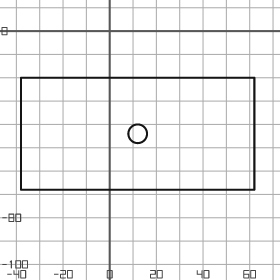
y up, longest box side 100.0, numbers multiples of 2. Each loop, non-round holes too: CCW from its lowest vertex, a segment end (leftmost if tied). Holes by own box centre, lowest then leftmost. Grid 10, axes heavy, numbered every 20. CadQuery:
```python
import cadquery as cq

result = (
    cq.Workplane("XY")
    .moveTo(-38.0, -68.0)
    .lineTo(62.0, -68.0)
    .lineTo(62.0, -20.0)
    .lineTo(-38.0, -20.0)
    .close()
    .moveTo(12.0, -44.0)
    .circle(4.0)
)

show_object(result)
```